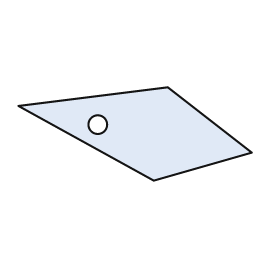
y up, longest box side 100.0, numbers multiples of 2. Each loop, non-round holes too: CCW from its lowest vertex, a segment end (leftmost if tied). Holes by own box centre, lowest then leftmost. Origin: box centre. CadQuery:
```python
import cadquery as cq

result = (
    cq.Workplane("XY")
    .moveTo(8.0, -20.0)
    .lineTo(50.0, -8.0)
    .lineTo(14.0, 20.0)
    .lineTo(-50.0, 12.0)
    .close()
    .moveTo(-16.0, 4.0)
    .circle(4.0)
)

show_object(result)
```